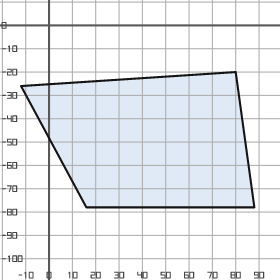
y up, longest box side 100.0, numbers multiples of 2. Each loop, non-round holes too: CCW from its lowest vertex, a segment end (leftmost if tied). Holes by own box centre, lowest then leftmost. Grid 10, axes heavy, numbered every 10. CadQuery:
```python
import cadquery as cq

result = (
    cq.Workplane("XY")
    .moveTo(16.0, -78.0)
    .lineTo(88.0, -78.0)
    .lineTo(80.0, -20.0)
    .lineTo(-12.0, -26.0)
    .close()
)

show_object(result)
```